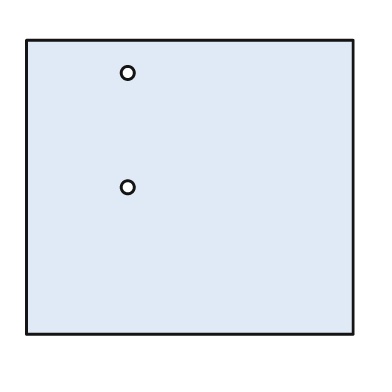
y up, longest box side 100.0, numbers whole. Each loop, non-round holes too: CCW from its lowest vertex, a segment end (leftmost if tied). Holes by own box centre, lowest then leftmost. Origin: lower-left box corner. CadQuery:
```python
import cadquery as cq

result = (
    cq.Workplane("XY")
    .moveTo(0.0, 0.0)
    .lineTo(100.0, 0.0)
    .lineTo(100.0, 90.0)
    .lineTo(0.0, 90.0)
    .close()
    .moveTo(31.0, 45.0)
    .circle(2.0)
    .moveTo(31.0, 80.0)
    .circle(2.0)
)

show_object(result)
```